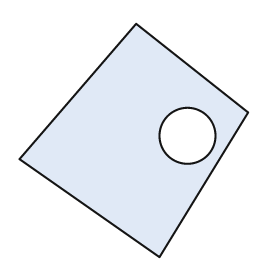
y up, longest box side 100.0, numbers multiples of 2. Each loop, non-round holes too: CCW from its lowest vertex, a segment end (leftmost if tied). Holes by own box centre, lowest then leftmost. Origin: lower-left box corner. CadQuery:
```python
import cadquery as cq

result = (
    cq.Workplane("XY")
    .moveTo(60.0, 0.0)
    .lineTo(98.0, 62.0)
    .lineTo(50.0, 100.0)
    .lineTo(0.0, 42.0)
    .close()
    .moveTo(72.0, 52.0)
    .circle(12.0)
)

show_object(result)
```